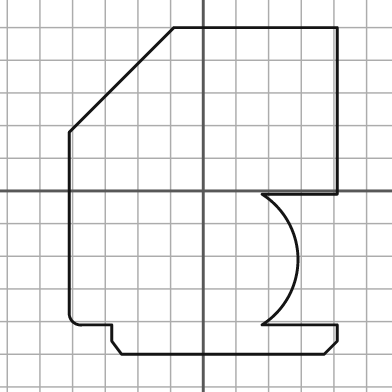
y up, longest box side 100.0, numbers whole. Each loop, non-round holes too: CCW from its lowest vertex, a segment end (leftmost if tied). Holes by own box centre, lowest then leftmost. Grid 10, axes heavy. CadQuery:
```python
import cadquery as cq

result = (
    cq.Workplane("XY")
    .moveTo(-25.0, -50.0)
    .lineTo(37.0, -50.0)
    .lineTo(41.0, -46.0)
    .lineTo(41.0, -41.0)
    .lineTo(18.0, -41.0)
    .threePointArc((29.0, -21.0), (18.0, -1.0))
    .lineTo(41.0, -1.0)
    .lineTo(41.0, 50.0)
    .lineTo(-9.0, 50.0)
    .lineTo(-41.0, 18.0)
    .lineTo(-41.0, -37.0)
    .threePointArc((-40.0, -40.0), (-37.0, -41.0))
    .lineTo(-28.0, -41.0)
    .lineTo(-28.0, -46.0)
    .close()
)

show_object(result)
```